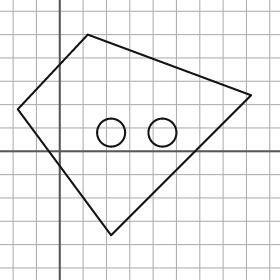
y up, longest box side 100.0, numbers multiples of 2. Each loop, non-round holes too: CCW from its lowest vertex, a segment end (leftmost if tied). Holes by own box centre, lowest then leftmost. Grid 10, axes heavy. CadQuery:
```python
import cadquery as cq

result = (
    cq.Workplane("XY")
    .moveTo(22.0, -36.0)
    .lineTo(82.0, 24.0)
    .lineTo(12.0, 50.0)
    .lineTo(-18.0, 18.0)
    .close()
    .moveTo(22.0, 8.0)
    .circle(6.0)
    .moveTo(44.0, 8.0)
    .circle(6.0)
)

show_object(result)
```